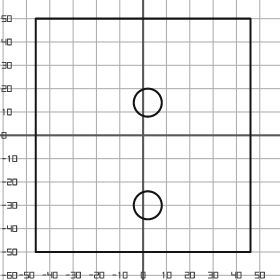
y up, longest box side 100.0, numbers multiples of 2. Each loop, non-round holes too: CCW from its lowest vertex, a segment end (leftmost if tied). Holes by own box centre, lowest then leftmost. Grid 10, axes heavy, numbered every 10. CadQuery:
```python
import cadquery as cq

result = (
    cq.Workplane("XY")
    .moveTo(-46.0, -50.0)
    .lineTo(46.0, -50.0)
    .lineTo(46.0, 50.0)
    .lineTo(-46.0, 50.0)
    .close()
    .moveTo(2.0, -30.0)
    .circle(6.0)
    .moveTo(2.0, 14.0)
    .circle(6.0)
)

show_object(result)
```